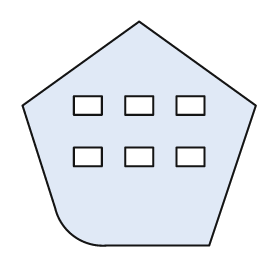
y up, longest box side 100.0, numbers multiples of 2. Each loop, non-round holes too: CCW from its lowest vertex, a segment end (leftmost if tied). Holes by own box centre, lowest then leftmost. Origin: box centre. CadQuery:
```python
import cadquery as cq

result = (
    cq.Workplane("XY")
    .moveTo(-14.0, -48.0)
    .lineTo(30.0, -48.0)
    .lineTo(50.0, 12.0)
    .lineTo(0.0, 48.0)
    .lineTo(-50.0, 12.0)
    .lineTo(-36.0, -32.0)
    .threePointArc((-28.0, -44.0), (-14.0, -48.0))
    .close()
    .moveTo(-28.0, -14.0)
    .lineTo(-16.0, -14.0)
    .lineTo(-16.0, -6.0)
    .lineTo(-28.0, -6.0)
    .close()
    .moveTo(-6.0, -14.0)
    .lineTo(6.0, -14.0)
    .lineTo(6.0, -6.0)
    .lineTo(-6.0, -6.0)
    .close()
    .moveTo(16.0, -14.0)
    .lineTo(28.0, -14.0)
    .lineTo(28.0, -6.0)
    .lineTo(16.0, -6.0)
    .close()
    .moveTo(-28.0, 8.0)
    .lineTo(-16.0, 8.0)
    .lineTo(-16.0, 16.0)
    .lineTo(-28.0, 16.0)
    .close()
    .moveTo(-6.0, 8.0)
    .lineTo(6.0, 8.0)
    .lineTo(6.0, 16.0)
    .lineTo(-6.0, 16.0)
    .close()
    .moveTo(16.0, 8.0)
    .lineTo(28.0, 8.0)
    .lineTo(28.0, 16.0)
    .lineTo(16.0, 16.0)
    .close()
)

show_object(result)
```